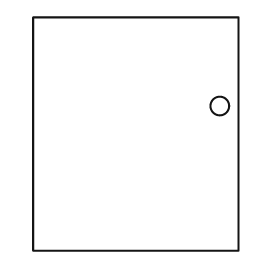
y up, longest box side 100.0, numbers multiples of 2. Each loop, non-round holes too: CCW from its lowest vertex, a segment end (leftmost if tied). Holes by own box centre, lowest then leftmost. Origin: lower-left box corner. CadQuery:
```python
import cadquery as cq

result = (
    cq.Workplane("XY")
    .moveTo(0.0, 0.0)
    .lineTo(88.0, 0.0)
    .lineTo(88.0, 100.0)
    .lineTo(0.0, 100.0)
    .close()
    .moveTo(80.0, 62.0)
    .circle(4.0)
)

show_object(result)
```